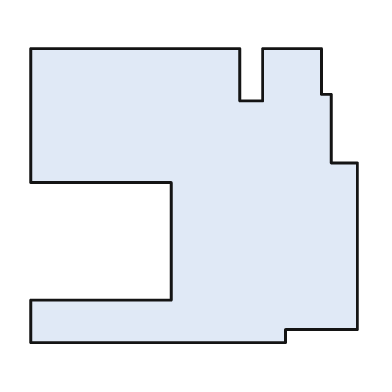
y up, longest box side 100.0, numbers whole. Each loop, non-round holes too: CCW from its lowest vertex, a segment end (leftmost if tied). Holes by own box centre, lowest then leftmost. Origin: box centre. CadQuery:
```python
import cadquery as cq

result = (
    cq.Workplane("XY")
    .moveTo(-50.0, -45.0)
    .lineTo(28.0, -45.0)
    .lineTo(28.0, -41.0)
    .lineTo(50.0, -41.0)
    .lineTo(50.0, 10.0)
    .lineTo(42.0, 10.0)
    .lineTo(42.0, 31.0)
    .lineTo(39.0, 31.0)
    .lineTo(39.0, 45.0)
    .lineTo(21.0, 45.0)
    .lineTo(21.0, 29.0)
    .lineTo(14.0, 29.0)
    .lineTo(14.0, 45.0)
    .lineTo(-50.0, 45.0)
    .lineTo(-50.0, 4.0)
    .lineTo(-7.0, 4.0)
    .lineTo(-7.0, -32.0)
    .lineTo(-50.0, -32.0)
    .close()
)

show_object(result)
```